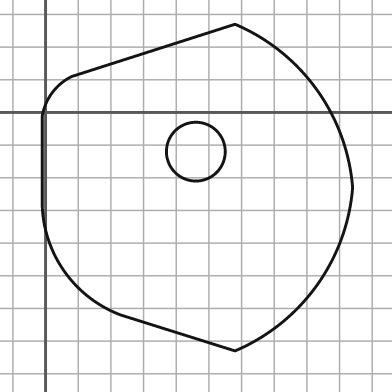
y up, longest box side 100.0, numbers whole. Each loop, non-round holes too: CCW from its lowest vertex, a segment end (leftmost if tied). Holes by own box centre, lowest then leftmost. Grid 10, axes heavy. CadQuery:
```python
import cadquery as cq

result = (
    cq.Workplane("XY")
    .moveTo(58.0, -73.0)
    .threePointArc((83.0, -53.0), (94.0, -23.0))
    .threePointArc((83.0, 7.0), (58.0, 27.0))
    .lineTo(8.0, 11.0)
    .threePointArc((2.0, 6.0), (-1.0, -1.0))
    .lineTo(-1.0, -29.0)
    .threePointArc((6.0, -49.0), (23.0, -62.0))
    .close()
    .moveTo(46.0, -12.0)
    .circle(9.0)
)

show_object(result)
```